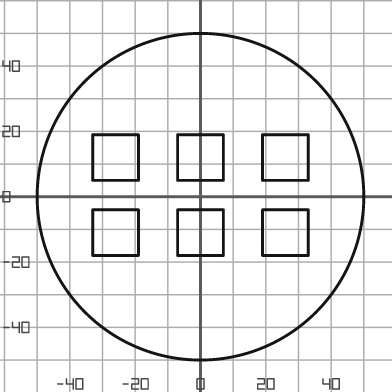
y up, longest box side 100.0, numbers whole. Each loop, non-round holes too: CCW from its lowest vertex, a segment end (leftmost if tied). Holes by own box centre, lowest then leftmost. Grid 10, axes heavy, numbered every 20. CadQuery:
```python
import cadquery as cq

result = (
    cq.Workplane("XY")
    .moveTo(0.0, 0.0)
    .circle(50.0)
    .moveTo(-33.0, -18.0)
    .lineTo(-19.0, -18.0)
    .lineTo(-19.0, -4.0)
    .lineTo(-33.0, -4.0)
    .close()
    .moveTo(-7.0, -18.0)
    .lineTo(7.0, -18.0)
    .lineTo(7.0, -4.0)
    .lineTo(-7.0, -4.0)
    .close()
    .moveTo(19.0, -18.0)
    .lineTo(33.0, -18.0)
    .lineTo(33.0, -4.0)
    .lineTo(19.0, -4.0)
    .close()
    .moveTo(-33.0, 5.0)
    .lineTo(-19.0, 5.0)
    .lineTo(-19.0, 19.0)
    .lineTo(-33.0, 19.0)
    .close()
    .moveTo(-7.0, 5.0)
    .lineTo(7.0, 5.0)
    .lineTo(7.0, 19.0)
    .lineTo(-7.0, 19.0)
    .close()
    .moveTo(19.0, 5.0)
    .lineTo(33.0, 5.0)
    .lineTo(33.0, 19.0)
    .lineTo(19.0, 19.0)
    .close()
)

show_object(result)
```